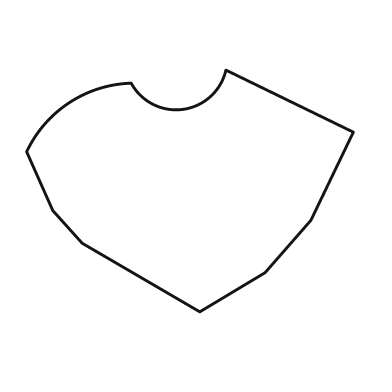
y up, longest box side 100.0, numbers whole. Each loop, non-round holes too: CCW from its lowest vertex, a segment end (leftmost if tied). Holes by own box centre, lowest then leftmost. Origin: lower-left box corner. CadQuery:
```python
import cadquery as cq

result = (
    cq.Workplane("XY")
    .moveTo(53.0, 0.0)
    .lineTo(73.0, 12.0)
    .lineTo(87.0, 28.0)
    .lineTo(100.0, 55.0)
    .lineTo(61.0, 74.0)
    .threePointArc((48.0, 62.0), (32.0, 70.0))
    .threePointArc((13.0, 64.0), (0.0, 49.0))
    .lineTo(8.0, 31.0)
    .lineTo(17.0, 21.0)
    .close()
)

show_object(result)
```